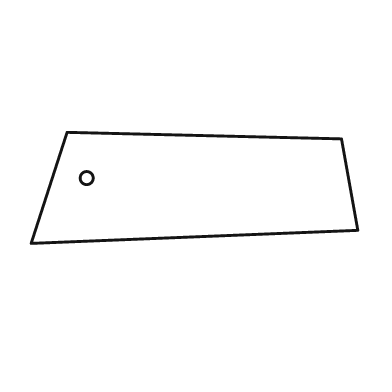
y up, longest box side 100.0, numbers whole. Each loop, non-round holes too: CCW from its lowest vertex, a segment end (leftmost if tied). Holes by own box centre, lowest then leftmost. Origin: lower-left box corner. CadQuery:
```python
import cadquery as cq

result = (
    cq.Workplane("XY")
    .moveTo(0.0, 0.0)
    .lineTo(100.0, 4.0)
    .lineTo(95.0, 32.0)
    .lineTo(11.0, 34.0)
    .close()
    .moveTo(17.0, 20.0)
    .circle(2.0)
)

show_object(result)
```